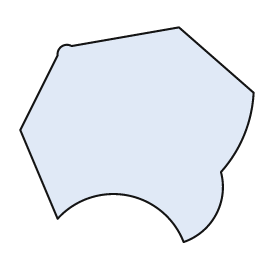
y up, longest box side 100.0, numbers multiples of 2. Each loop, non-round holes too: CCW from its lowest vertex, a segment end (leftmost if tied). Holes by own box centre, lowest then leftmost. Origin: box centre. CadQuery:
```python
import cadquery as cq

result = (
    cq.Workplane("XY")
    .moveTo(20.0, -46.0)
    .threePointArc((34.0, -34.0), (36.0, -16.0))
    .threePointArc((46.0, 0.0), (50.0, 18.0))
    .lineTo(18.0, 46.0)
    .lineTo(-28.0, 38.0)
    .threePointArc((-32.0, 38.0), (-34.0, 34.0))
    .lineTo(-50.0, 2.0)
    .lineTo(-34.0, -36.0)
    .threePointArc((-4.0, -26.0), (20.0, -46.0))
    .close()
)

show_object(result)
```